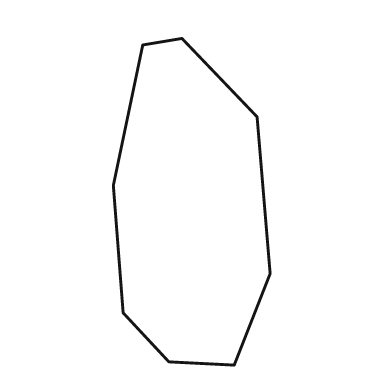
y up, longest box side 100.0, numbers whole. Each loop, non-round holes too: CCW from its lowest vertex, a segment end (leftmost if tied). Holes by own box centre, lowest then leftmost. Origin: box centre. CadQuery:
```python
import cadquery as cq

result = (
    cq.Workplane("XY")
    .moveTo(13.0, -50.0)
    .lineTo(24.0, -22.0)
    .lineTo(20.0, 26.0)
    .lineTo(-3.0, 50.0)
    .lineTo(-15.0, 48.0)
    .lineTo(-24.0, 5.0)
    .lineTo(-21.0, -34.0)
    .lineTo(-7.0, -49.0)
    .close()
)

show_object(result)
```